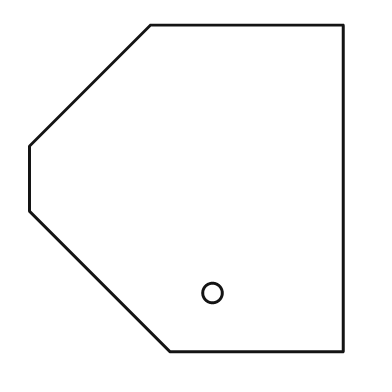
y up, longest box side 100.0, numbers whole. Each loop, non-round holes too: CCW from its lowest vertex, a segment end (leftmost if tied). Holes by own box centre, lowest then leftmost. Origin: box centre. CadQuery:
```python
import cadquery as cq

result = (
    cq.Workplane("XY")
    .moveTo(-5.0, -50.0)
    .lineTo(48.0, -50.0)
    .lineTo(48.0, 50.0)
    .lineTo(-11.0, 50.0)
    .lineTo(-48.0, 13.0)
    .lineTo(-48.0, -7.0)
    .close()
    .moveTo(8.0, -32.0)
    .circle(3.0)
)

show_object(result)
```